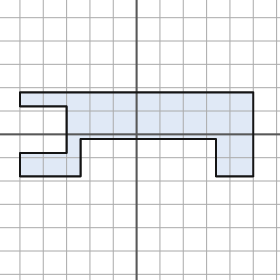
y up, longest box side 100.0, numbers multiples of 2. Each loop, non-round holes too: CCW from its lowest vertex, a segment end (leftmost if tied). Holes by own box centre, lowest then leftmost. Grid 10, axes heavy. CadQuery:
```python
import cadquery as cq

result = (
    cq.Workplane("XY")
    .moveTo(-50.0, -18.0)
    .lineTo(-24.0, -18.0)
    .lineTo(-24.0, -2.0)
    .lineTo(34.0, -2.0)
    .lineTo(34.0, -18.0)
    .lineTo(50.0, -18.0)
    .lineTo(50.0, 18.0)
    .lineTo(-50.0, 18.0)
    .lineTo(-50.0, 12.0)
    .lineTo(-30.0, 12.0)
    .lineTo(-30.0, -8.0)
    .lineTo(-50.0, -8.0)
    .close()
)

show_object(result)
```